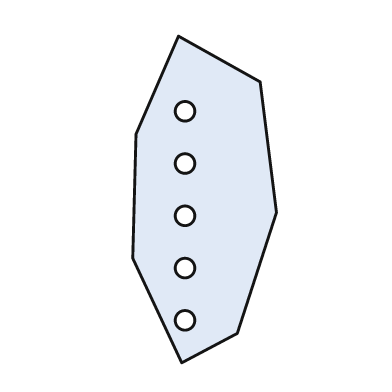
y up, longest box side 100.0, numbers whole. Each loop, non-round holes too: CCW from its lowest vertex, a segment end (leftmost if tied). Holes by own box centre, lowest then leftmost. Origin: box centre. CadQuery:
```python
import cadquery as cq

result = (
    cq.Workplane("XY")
    .moveTo(-7.0, -50.0)
    .lineTo(10.0, -41.0)
    .lineTo(22.0, -4.0)
    .lineTo(17.0, 36.0)
    .lineTo(-8.0, 50.0)
    .lineTo(-21.0, 20.0)
    .lineTo(-22.0, -18.0)
    .close()
    .moveTo(-6.0, -37.0)
    .circle(3.0)
    .moveTo(-6.0, -21.0)
    .circle(3.0)
    .moveTo(-6.0, -5.0)
    .circle(3.0)
    .moveTo(-6.0, 11.0)
    .circle(3.0)
    .moveTo(-6.0, 27.0)
    .circle(3.0)
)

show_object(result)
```